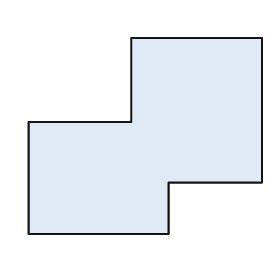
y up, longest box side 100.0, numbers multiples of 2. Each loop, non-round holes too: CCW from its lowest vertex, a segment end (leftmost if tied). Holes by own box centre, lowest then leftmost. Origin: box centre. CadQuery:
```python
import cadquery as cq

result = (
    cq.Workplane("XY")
    .moveTo(-50.0, -42.0)
    .lineTo(10.0, -42.0)
    .lineTo(10.0, -20.0)
    .lineTo(50.0, -20.0)
    .lineTo(50.0, 42.0)
    .lineTo(-6.0, 42.0)
    .lineTo(-6.0, 6.0)
    .lineTo(-50.0, 6.0)
    .close()
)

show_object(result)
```